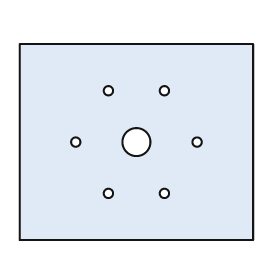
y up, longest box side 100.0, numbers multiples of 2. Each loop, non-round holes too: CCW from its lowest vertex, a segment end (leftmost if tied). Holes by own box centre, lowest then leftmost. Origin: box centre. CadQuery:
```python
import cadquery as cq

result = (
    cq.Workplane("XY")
    .moveTo(-50.0, -42.0)
    .lineTo(50.0, -42.0)
    .lineTo(50.0, 42.0)
    .lineTo(-50.0, 42.0)
    .close()
    .moveTo(-12.0, -22.0)
    .circle(2.0)
    .moveTo(12.0, -22.0)
    .circle(2.0)
    .moveTo(-26.0, 0.0)
    .circle(2.0)
    .moveTo(0.0, 0.0)
    .circle(6.0)
    .moveTo(26.0, 0.0)
    .circle(2.0)
    .moveTo(-12.0, 22.0)
    .circle(2.0)
    .moveTo(12.0, 22.0)
    .circle(2.0)
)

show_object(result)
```